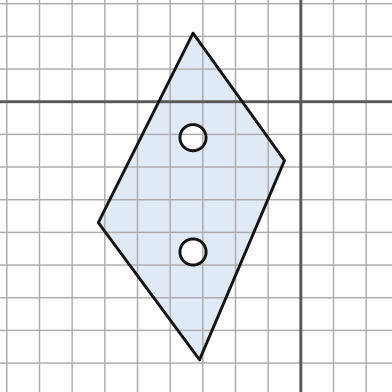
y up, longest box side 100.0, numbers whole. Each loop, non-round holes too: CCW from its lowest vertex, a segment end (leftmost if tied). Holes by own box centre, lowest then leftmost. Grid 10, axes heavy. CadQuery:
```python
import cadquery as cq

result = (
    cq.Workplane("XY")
    .moveTo(-31.0, -79.0)
    .lineTo(-5.0, -18.0)
    .lineTo(-33.0, 21.0)
    .lineTo(-62.0, -37.0)
    .close()
    .moveTo(-33.0, -46.0)
    .circle(4.0)
    .moveTo(-33.0, -11.0)
    .circle(4.0)
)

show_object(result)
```